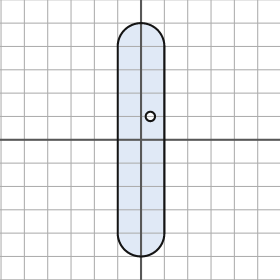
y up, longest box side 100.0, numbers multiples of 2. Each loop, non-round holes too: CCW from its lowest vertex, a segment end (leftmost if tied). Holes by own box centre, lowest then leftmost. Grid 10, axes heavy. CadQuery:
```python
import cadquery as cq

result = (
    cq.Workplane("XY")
    .moveTo(-10.0, -40.0)
    .threePointArc((0.0, -50.0), (10.0, -40.0))
    .lineTo(10.0, 40.0)
    .threePointArc((0.0, 50.0), (-10.0, 40.0))
    .close()
    .moveTo(4.0, 10.0)
    .circle(2.0)
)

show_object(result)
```